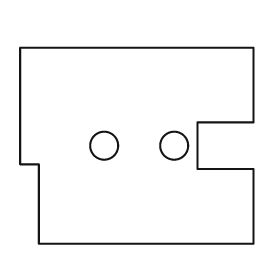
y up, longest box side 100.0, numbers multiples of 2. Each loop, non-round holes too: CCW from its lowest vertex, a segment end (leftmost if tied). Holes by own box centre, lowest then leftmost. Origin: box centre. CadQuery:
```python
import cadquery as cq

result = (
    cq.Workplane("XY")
    .moveTo(-42.0, -42.0)
    .lineTo(50.0, -42.0)
    .lineTo(50.0, -10.0)
    .lineTo(26.0, -10.0)
    .lineTo(26.0, 10.0)
    .lineTo(50.0, 10.0)
    .lineTo(50.0, 42.0)
    .lineTo(-50.0, 42.0)
    .lineTo(-50.0, -8.0)
    .lineTo(-42.0, -8.0)
    .close()
    .moveTo(-14.0, 0.0)
    .circle(6.0)
    .moveTo(16.0, 0.0)
    .circle(6.0)
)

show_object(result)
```